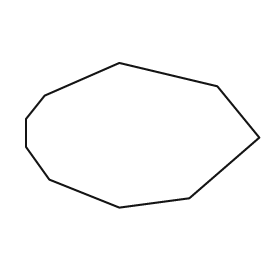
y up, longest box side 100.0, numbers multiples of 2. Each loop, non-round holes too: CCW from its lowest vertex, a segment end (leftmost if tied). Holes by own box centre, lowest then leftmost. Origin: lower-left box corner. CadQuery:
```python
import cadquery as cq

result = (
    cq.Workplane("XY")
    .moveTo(40.0, 0.0)
    .lineTo(70.0, 4.0)
    .lineTo(100.0, 30.0)
    .lineTo(82.0, 52.0)
    .lineTo(40.0, 62.0)
    .lineTo(8.0, 48.0)
    .lineTo(0.0, 38.0)
    .lineTo(0.0, 26.0)
    .lineTo(10.0, 12.0)
    .close()
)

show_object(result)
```